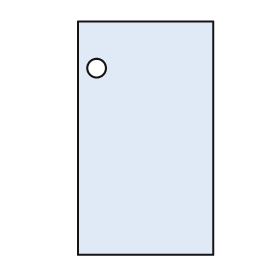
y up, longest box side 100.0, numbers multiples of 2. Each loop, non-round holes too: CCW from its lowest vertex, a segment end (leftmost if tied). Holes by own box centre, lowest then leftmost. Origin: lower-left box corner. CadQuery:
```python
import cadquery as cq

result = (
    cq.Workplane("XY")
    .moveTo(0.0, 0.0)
    .lineTo(58.0, 0.0)
    .lineTo(58.0, 100.0)
    .lineTo(0.0, 100.0)
    .close()
    .moveTo(8.0, 80.0)
    .circle(4.0)
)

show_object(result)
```